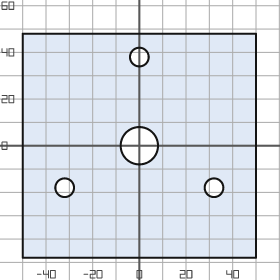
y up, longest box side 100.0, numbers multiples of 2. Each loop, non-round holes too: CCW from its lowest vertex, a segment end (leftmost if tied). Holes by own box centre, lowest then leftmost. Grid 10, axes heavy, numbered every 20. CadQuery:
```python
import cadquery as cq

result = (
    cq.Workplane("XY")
    .moveTo(-50.0, -48.0)
    .lineTo(50.0, -48.0)
    .lineTo(50.0, 48.0)
    .lineTo(-50.0, 48.0)
    .close()
    .moveTo(-32.0, -18.0)
    .circle(4.0)
    .moveTo(32.0, -18.0)
    .circle(4.0)
    .moveTo(0.0, 0.0)
    .circle(8.0)
    .moveTo(0.0, 38.0)
    .circle(4.0)
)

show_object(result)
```